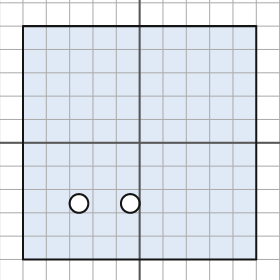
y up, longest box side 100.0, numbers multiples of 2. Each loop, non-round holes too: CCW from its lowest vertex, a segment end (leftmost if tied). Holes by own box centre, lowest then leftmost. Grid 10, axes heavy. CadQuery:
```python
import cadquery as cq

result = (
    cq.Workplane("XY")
    .moveTo(-50.0, -50.0)
    .lineTo(50.0, -50.0)
    .lineTo(50.0, 50.0)
    .lineTo(-50.0, 50.0)
    .close()
    .moveTo(-26.0, -26.0)
    .circle(4.0)
    .moveTo(-4.0, -26.0)
    .circle(4.0)
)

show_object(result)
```